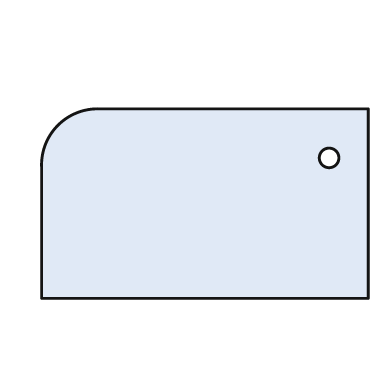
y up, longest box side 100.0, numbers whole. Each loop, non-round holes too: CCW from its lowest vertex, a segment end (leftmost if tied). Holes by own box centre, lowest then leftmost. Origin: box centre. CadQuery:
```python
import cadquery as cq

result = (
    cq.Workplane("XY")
    .moveTo(-50.0, -29.0)
    .lineTo(50.0, -29.0)
    .lineTo(50.0, 29.0)
    .lineTo(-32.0, 29.0)
    .threePointArc((-45.0, 24.0), (-50.0, 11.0))
    .close()
    .moveTo(38.0, 14.0)
    .circle(3.0)
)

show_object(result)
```